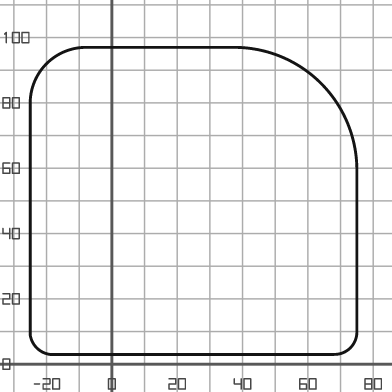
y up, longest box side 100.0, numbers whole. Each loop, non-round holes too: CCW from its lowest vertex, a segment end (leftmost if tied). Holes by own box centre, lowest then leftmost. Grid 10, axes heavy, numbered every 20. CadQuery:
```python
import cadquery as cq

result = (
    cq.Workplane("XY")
    .moveTo(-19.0, 3.0)
    .lineTo(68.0, 3.0)
    .threePointArc((73.0, 5.0), (75.0, 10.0))
    .lineTo(75.0, 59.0)
    .threePointArc((64.0, 86.0), (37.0, 97.0))
    .lineTo(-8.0, 97.0)
    .threePointArc((-20.0, 92.0), (-25.0, 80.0))
    .lineTo(-25.0, 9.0)
    .threePointArc((-23.0, 5.0), (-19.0, 3.0))
    .close()
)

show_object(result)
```